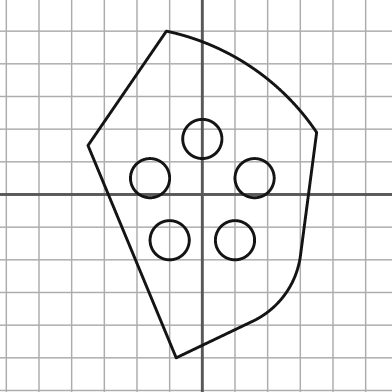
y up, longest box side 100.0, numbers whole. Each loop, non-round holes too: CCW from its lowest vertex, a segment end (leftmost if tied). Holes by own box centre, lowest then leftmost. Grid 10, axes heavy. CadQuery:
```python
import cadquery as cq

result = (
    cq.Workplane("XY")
    .moveTo(-8.0, -50.0)
    .lineTo(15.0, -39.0)
    .threePointArc((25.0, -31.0), (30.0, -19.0))
    .lineTo(35.0, 19.0)
    .threePointArc((15.0, 39.0), (-11.0, 50.0))
    .lineTo(-35.0, 15.0)
    .close()
    .moveTo(-10.0, -14.0)
    .circle(6.0)
    .moveTo(10.0, -14.0)
    .circle(6.0)
    .moveTo(-16.0, 5.0)
    .circle(6.0)
    .moveTo(16.0, 5.0)
    .circle(6.0)
    .moveTo(0.0, 17.0)
    .circle(6.0)
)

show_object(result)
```